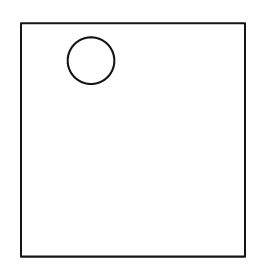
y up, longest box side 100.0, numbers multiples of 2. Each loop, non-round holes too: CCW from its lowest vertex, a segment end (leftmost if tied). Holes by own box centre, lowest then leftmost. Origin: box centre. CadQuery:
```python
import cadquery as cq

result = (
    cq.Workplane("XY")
    .moveTo(-48.0, -50.0)
    .lineTo(48.0, -50.0)
    .lineTo(48.0, 50.0)
    .lineTo(-48.0, 50.0)
    .close()
    .moveTo(-18.0, 34.0)
    .circle(10.0)
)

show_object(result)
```